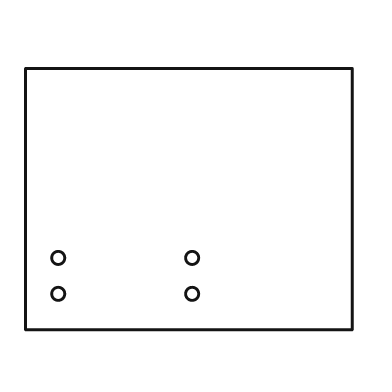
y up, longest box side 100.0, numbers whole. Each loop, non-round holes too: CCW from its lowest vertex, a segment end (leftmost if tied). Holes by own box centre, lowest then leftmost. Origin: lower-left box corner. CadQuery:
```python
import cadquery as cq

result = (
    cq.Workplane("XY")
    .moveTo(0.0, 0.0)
    .lineTo(100.0, 0.0)
    .lineTo(100.0, 80.0)
    .lineTo(0.0, 80.0)
    .close()
    .moveTo(10.0, 11.0)
    .circle(2.0)
    .moveTo(51.0, 11.0)
    .circle(2.0)
    .moveTo(10.0, 22.0)
    .circle(2.0)
    .moveTo(51.0, 22.0)
    .circle(2.0)
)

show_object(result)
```